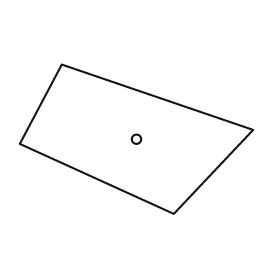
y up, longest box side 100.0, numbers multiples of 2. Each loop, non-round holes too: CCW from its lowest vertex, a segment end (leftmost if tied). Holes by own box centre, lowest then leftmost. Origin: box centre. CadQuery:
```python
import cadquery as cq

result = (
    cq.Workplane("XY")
    .moveTo(16.0, -32.0)
    .lineTo(50.0, 4.0)
    .lineTo(-32.0, 32.0)
    .lineTo(-50.0, -2.0)
    .close()
    .moveTo(0.0, 0.0)
    .circle(2.0)
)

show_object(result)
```